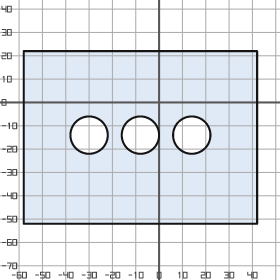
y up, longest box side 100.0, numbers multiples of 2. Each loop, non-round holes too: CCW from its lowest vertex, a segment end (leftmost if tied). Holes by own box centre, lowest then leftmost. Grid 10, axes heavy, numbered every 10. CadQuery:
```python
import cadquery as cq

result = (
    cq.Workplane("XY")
    .moveTo(-58.0, -52.0)
    .lineTo(42.0, -52.0)
    .lineTo(42.0, 22.0)
    .lineTo(-58.0, 22.0)
    .close()
    .moveTo(-30.0, -14.0)
    .circle(8.0)
    .moveTo(-8.0, -14.0)
    .circle(8.0)
    .moveTo(14.0, -14.0)
    .circle(8.0)
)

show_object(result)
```